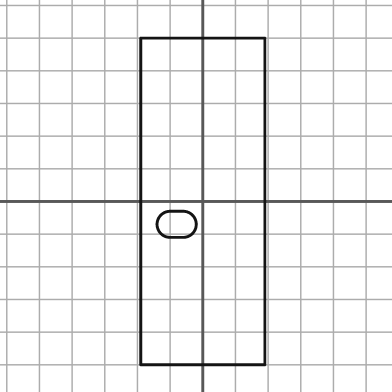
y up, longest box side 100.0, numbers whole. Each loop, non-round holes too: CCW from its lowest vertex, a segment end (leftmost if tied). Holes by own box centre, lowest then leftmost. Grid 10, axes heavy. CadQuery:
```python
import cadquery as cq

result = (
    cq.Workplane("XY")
    .moveTo(-19.0, -50.0)
    .lineTo(19.0, -50.0)
    .lineTo(19.0, 50.0)
    .lineTo(-19.0, 50.0)
    .close()
    .moveTo(-10.0, -11.0)
    .lineTo(-6.0, -11.0)
    .threePointArc((-2.0, -7.0), (-6.0, -3.0))
    .lineTo(-10.0, -3.0)
    .threePointArc((-14.0, -7.0), (-10.0, -11.0))
    .close()
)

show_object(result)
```